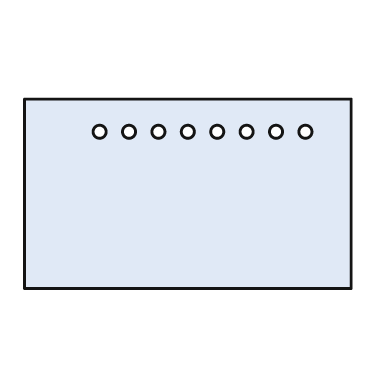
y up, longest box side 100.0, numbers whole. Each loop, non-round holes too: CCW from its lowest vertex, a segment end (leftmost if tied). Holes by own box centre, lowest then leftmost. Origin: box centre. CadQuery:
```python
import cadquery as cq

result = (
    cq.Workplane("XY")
    .moveTo(-50.0, -29.0)
    .lineTo(50.0, -29.0)
    .lineTo(50.0, 29.0)
    .lineTo(-50.0, 29.0)
    .close()
    .moveTo(-27.0, 19.0)
    .circle(2.0)
    .moveTo(-18.0, 19.0)
    .circle(2.0)
    .moveTo(-9.0, 19.0)
    .circle(2.0)
    .moveTo(0.0, 19.0)
    .circle(2.0)
    .moveTo(9.0, 19.0)
    .circle(2.0)
    .moveTo(18.0, 19.0)
    .circle(2.0)
    .moveTo(27.0, 19.0)
    .circle(2.0)
    .moveTo(36.0, 19.0)
    .circle(2.0)
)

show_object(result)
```